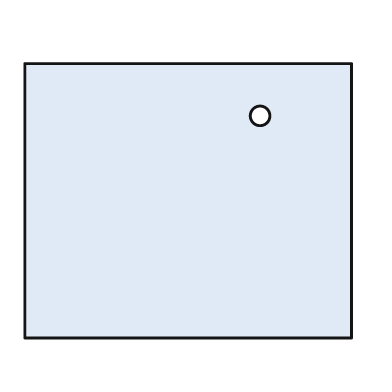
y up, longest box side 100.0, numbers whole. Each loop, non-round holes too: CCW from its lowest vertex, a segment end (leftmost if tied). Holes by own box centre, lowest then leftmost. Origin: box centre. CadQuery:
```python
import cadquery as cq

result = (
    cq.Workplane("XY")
    .moveTo(-50.0, -42.0)
    .lineTo(50.0, -42.0)
    .lineTo(50.0, 42.0)
    .lineTo(-50.0, 42.0)
    .close()
    .moveTo(22.0, 26.0)
    .circle(3.0)
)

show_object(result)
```